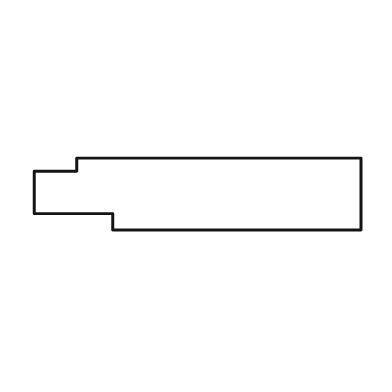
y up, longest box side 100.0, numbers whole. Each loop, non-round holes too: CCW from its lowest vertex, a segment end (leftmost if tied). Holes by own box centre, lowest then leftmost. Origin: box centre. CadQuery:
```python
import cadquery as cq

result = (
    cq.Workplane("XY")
    .moveTo(-26.0, -11.0)
    .lineTo(50.0, -11.0)
    .lineTo(50.0, 11.0)
    .lineTo(-37.0, 11.0)
    .lineTo(-37.0, 7.0)
    .lineTo(-50.0, 7.0)
    .lineTo(-50.0, -6.0)
    .lineTo(-26.0, -6.0)
    .close()
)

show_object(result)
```